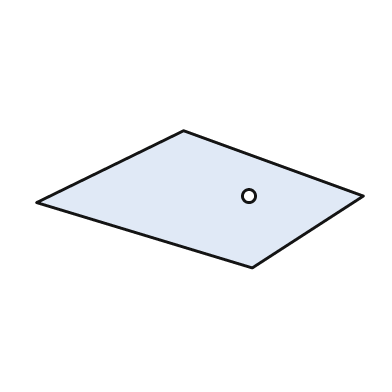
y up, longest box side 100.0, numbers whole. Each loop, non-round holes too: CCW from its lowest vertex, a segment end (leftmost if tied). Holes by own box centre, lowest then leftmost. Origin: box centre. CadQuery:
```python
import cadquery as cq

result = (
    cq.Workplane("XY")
    .moveTo(16.0, -21.0)
    .lineTo(50.0, 1.0)
    .lineTo(-5.0, 21.0)
    .lineTo(-50.0, -1.0)
    .close()
    .moveTo(15.0, 1.0)
    .circle(2.0)
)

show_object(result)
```